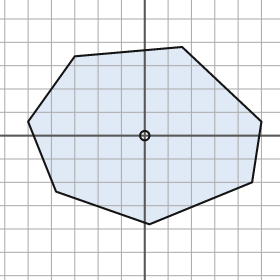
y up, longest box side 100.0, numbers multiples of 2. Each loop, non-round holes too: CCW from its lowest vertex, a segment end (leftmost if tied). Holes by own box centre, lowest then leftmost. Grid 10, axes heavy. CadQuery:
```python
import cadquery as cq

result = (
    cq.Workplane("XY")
    .moveTo(2.0, -38.0)
    .lineTo(46.0, -20.0)
    .lineTo(50.0, 6.0)
    .lineTo(16.0, 38.0)
    .lineTo(-30.0, 34.0)
    .lineTo(-50.0, 6.0)
    .lineTo(-38.0, -24.0)
    .close()
    .moveTo(0.0, 0.0)
    .circle(2.0)
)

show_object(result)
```